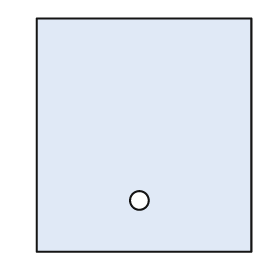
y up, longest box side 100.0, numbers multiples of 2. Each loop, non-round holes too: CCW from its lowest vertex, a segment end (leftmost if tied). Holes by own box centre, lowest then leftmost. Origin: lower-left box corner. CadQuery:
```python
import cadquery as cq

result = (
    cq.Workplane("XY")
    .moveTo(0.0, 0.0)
    .lineTo(92.0, 0.0)
    .lineTo(92.0, 100.0)
    .lineTo(0.0, 100.0)
    .close()
    .moveTo(44.0, 22.0)
    .circle(4.0)
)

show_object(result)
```